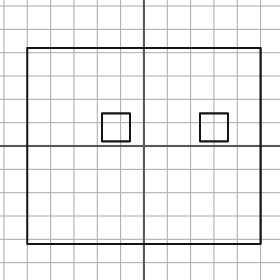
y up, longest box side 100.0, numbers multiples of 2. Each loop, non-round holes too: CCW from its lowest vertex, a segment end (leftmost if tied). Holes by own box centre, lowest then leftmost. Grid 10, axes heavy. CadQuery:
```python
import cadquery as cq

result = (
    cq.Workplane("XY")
    .moveTo(-50.0, -42.0)
    .lineTo(50.0, -42.0)
    .lineTo(50.0, 42.0)
    .lineTo(-50.0, 42.0)
    .close()
    .moveTo(-18.0, 2.0)
    .lineTo(-6.0, 2.0)
    .lineTo(-6.0, 14.0)
    .lineTo(-18.0, 14.0)
    .close()
    .moveTo(24.0, 2.0)
    .lineTo(36.0, 2.0)
    .lineTo(36.0, 14.0)
    .lineTo(24.0, 14.0)
    .close()
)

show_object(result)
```